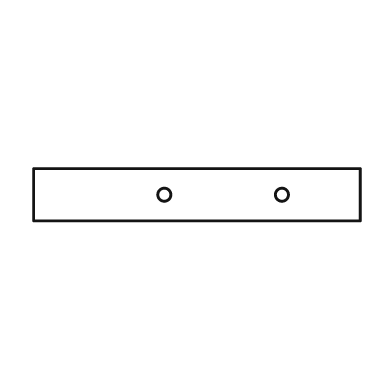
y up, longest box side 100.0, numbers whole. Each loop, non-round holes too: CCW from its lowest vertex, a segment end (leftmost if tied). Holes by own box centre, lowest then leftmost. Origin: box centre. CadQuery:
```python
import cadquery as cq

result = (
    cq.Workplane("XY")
    .moveTo(-50.0, -8.0)
    .lineTo(50.0, -8.0)
    .lineTo(50.0, 8.0)
    .lineTo(-50.0, 8.0)
    .close()
    .moveTo(-10.0, 0.0)
    .circle(2.0)
    .moveTo(26.0, 0.0)
    .circle(2.0)
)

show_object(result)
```